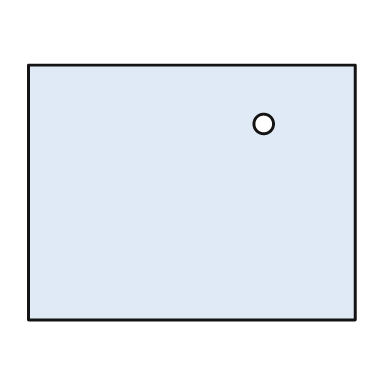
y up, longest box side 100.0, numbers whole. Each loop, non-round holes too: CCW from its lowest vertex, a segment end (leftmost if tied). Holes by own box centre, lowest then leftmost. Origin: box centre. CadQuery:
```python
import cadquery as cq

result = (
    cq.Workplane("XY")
    .moveTo(-50.0, -39.0)
    .lineTo(50.0, -39.0)
    .lineTo(50.0, 39.0)
    .lineTo(-50.0, 39.0)
    .close()
    .moveTo(22.0, 21.0)
    .circle(3.0)
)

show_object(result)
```